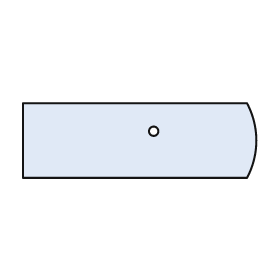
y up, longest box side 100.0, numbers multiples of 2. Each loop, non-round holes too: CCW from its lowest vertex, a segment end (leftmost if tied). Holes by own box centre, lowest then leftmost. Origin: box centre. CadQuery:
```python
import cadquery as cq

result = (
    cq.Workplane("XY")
    .moveTo(-50.0, -16.0)
    .lineTo(46.0, -16.0)
    .threePointArc((50.0, 0.0), (46.0, 16.0))
    .lineTo(-50.0, 16.0)
    .close()
    .moveTo(6.0, 4.0)
    .circle(2.0)
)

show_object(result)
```